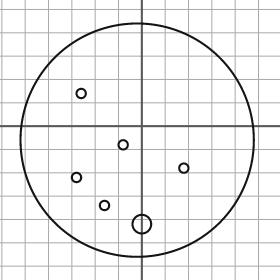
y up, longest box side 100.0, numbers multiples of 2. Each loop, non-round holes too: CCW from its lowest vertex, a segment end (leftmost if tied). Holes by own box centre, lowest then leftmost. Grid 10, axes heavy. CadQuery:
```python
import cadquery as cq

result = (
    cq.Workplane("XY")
    .moveTo(-2.0, -6.0)
    .circle(50.0)
    .moveTo(0.0, -42.0)
    .circle(4.0)
    .moveTo(-16.0, -34.0)
    .circle(2.0)
    .moveTo(-28.0, -22.0)
    .circle(2.0)
    .moveTo(18.0, -18.0)
    .circle(2.0)
    .moveTo(-8.0, -8.0)
    .circle(2.0)
    .moveTo(-26.0, 14.0)
    .circle(2.0)
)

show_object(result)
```